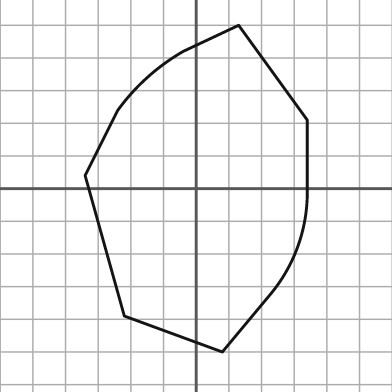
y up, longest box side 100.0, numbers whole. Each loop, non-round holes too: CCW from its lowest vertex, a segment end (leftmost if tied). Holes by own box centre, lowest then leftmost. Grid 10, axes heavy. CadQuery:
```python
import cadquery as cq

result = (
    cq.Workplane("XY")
    .moveTo(8.0, -50.0)
    .lineTo(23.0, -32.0)
    .threePointArc((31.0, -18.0), (34.0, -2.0))
    .lineTo(34.0, 21.0)
    .lineTo(13.0, 50.0)
    .lineTo(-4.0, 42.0)
    .threePointArc((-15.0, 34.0), (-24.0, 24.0))
    .lineTo(-34.0, 4.0)
    .lineTo(-22.0, -39.0)
    .close()
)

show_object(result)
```